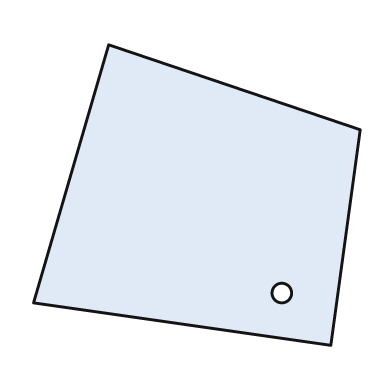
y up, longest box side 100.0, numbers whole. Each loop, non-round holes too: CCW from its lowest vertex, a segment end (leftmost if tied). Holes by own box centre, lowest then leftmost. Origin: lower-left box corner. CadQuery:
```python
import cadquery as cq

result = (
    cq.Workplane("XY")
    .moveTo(91.0, 0.0)
    .lineTo(100.0, 66.0)
    .lineTo(23.0, 92.0)
    .lineTo(0.0, 13.0)
    .close()
    .moveTo(76.0, 16.0)
    .circle(3.0)
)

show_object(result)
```